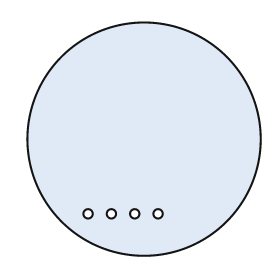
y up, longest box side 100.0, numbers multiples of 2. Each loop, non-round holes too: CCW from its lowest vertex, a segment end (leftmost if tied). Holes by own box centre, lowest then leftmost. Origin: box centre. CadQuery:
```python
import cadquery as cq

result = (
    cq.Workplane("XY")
    .moveTo(0.0, 0.0)
    .circle(50.0)
    .moveTo(-24.0, -32.0)
    .circle(2.0)
    .moveTo(-14.0, -32.0)
    .circle(2.0)
    .moveTo(-4.0, -32.0)
    .circle(2.0)
    .moveTo(6.0, -32.0)
    .circle(2.0)
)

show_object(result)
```